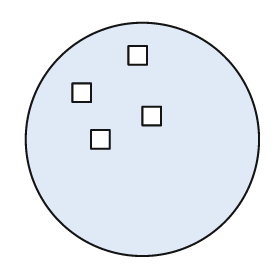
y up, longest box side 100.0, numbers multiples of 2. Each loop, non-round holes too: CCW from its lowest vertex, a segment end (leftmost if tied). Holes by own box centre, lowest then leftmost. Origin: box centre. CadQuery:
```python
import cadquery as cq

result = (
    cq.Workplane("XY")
    .moveTo(0.0, 0.0)
    .circle(50.0)
    .moveTo(-22.0, -4.0)
    .lineTo(-14.0, -4.0)
    .lineTo(-14.0, 4.0)
    .lineTo(-22.0, 4.0)
    .close()
    .moveTo(0.0, 6.0)
    .lineTo(8.0, 6.0)
    .lineTo(8.0, 14.0)
    .lineTo(0.0, 14.0)
    .close()
    .moveTo(-30.0, 16.0)
    .lineTo(-22.0, 16.0)
    .lineTo(-22.0, 24.0)
    .lineTo(-30.0, 24.0)
    .close()
    .moveTo(-6.0, 32.0)
    .lineTo(2.0, 32.0)
    .lineTo(2.0, 40.0)
    .lineTo(-6.0, 40.0)
    .close()
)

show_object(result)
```